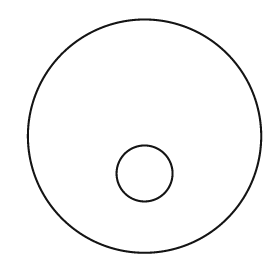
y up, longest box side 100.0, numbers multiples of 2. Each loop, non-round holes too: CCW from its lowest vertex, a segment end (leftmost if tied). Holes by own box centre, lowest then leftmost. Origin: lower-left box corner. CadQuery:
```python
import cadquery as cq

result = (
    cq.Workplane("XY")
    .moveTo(50.0, 50.0)
    .circle(50.0)
    .moveTo(50.0, 34.0)
    .circle(12.0)
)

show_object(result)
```